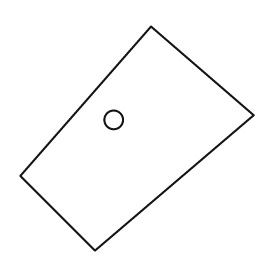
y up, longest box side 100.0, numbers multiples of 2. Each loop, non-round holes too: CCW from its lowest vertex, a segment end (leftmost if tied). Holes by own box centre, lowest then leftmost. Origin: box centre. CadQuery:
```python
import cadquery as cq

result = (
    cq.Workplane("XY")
    .moveTo(-18.0, -48.0)
    .lineTo(50.0, 10.0)
    .lineTo(6.0, 48.0)
    .lineTo(-50.0, -16.0)
    .close()
    .moveTo(-10.0, 8.0)
    .circle(4.0)
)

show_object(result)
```